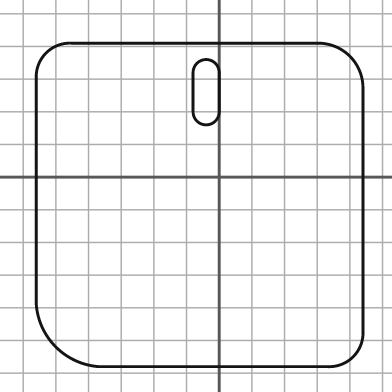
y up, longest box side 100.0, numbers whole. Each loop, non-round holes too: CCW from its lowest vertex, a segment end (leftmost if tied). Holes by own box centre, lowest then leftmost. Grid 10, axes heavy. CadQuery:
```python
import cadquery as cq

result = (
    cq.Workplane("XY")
    .moveTo(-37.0, -58.0)
    .lineTo(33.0, -58.0)
    .threePointArc((41.0, -55.0), (44.0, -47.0))
    .lineTo(44.0, 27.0)
    .threePointArc((40.0, 37.0), (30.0, 41.0))
    .lineTo(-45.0, 41.0)
    .threePointArc((-53.0, 38.0), (-56.0, 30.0))
    .lineTo(-56.0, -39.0)
    .threePointArc((-50.0, -52.0), (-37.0, -58.0))
    .close()
    .moveTo(-8.0, 20.0)
    .threePointArc((-4.0, 16.0), (0.0, 20.0))
    .lineTo(0.0, 32.0)
    .threePointArc((-4.0, 36.0), (-8.0, 32.0))
    .close()
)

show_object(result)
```